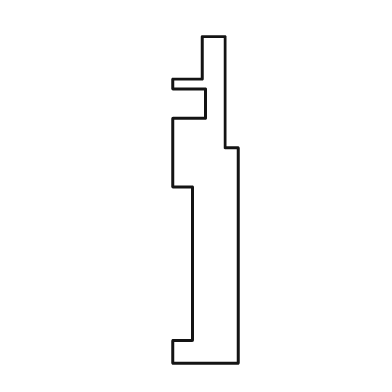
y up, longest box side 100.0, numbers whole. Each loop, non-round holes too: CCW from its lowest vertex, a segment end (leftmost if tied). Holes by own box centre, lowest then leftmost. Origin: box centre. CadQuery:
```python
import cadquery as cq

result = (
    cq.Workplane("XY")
    .moveTo(-10.0, -50.0)
    .lineTo(10.0, -50.0)
    .lineTo(10.0, 16.0)
    .lineTo(6.0, 16.0)
    .lineTo(6.0, 50.0)
    .lineTo(-1.0, 50.0)
    .lineTo(-1.0, 37.0)
    .lineTo(-10.0, 37.0)
    .lineTo(-10.0, 34.0)
    .lineTo(0.0, 34.0)
    .lineTo(0.0, 25.0)
    .lineTo(-10.0, 25.0)
    .lineTo(-10.0, 4.0)
    .lineTo(-4.0, 4.0)
    .lineTo(-4.0, -43.0)
    .lineTo(-10.0, -43.0)
    .close()
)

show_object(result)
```